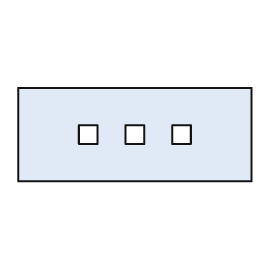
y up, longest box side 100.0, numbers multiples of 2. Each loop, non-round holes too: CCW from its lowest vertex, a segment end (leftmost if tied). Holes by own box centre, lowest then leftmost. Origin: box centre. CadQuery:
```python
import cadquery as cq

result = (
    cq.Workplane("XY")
    .moveTo(-50.0, -20.0)
    .lineTo(50.0, -20.0)
    .lineTo(50.0, 20.0)
    .lineTo(-50.0, 20.0)
    .close()
    .moveTo(-24.0, -4.0)
    .lineTo(-16.0, -4.0)
    .lineTo(-16.0, 4.0)
    .lineTo(-24.0, 4.0)
    .close()
    .moveTo(-4.0, -4.0)
    .lineTo(4.0, -4.0)
    .lineTo(4.0, 4.0)
    .lineTo(-4.0, 4.0)
    .close()
    .moveTo(16.0, -4.0)
    .lineTo(24.0, -4.0)
    .lineTo(24.0, 4.0)
    .lineTo(16.0, 4.0)
    .close()
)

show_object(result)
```